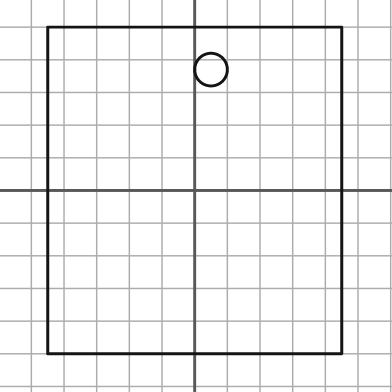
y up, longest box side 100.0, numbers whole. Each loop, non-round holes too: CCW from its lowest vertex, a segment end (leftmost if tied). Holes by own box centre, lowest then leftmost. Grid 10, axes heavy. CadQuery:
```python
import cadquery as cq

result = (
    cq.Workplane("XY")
    .moveTo(-45.0, -50.0)
    .lineTo(45.0, -50.0)
    .lineTo(45.0, 50.0)
    .lineTo(-45.0, 50.0)
    .close()
    .moveTo(5.0, 37.0)
    .circle(5.0)
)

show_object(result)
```